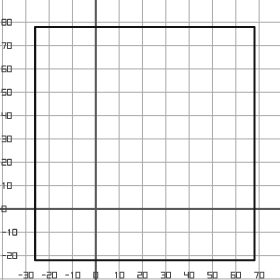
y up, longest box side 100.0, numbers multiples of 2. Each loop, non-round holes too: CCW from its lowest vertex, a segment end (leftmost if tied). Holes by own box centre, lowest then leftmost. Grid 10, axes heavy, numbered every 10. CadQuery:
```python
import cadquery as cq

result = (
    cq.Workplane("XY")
    .moveTo(-26.0, -22.0)
    .lineTo(68.0, -22.0)
    .lineTo(68.0, 78.0)
    .lineTo(-26.0, 78.0)
    .close()
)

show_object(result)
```